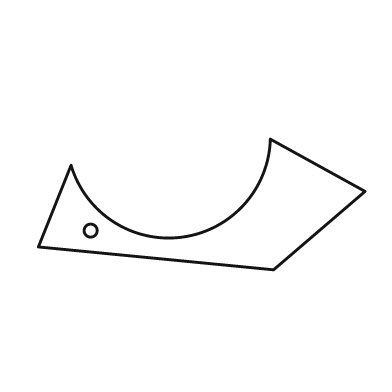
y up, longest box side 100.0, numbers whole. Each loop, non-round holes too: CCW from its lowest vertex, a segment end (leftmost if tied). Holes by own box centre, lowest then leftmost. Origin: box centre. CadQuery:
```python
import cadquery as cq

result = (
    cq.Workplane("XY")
    .moveTo(22.0, -20.0)
    .lineTo(50.0, 4.0)
    .lineTo(21.0, 20.0)
    .threePointArc((-6.0, -10.0), (-40.0, 12.0))
    .lineTo(-50.0, -13.0)
    .close()
    .moveTo(-34.0, -8.0)
    .circle(2.0)
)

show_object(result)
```